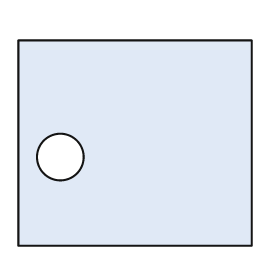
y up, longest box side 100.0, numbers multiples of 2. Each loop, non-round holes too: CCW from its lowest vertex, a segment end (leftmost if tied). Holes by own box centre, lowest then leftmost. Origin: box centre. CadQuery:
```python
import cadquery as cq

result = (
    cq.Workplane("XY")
    .moveTo(-50.0, -44.0)
    .lineTo(50.0, -44.0)
    .lineTo(50.0, 44.0)
    .lineTo(-50.0, 44.0)
    .close()
    .moveTo(-32.0, -6.0)
    .circle(10.0)
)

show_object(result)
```